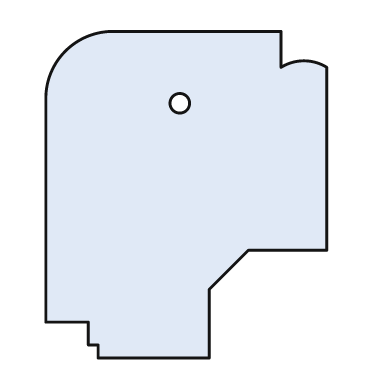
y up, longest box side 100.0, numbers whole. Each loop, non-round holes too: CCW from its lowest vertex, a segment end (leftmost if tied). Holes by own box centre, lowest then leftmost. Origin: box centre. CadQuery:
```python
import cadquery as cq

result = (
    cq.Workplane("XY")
    .moveTo(-27.0, -50.0)
    .lineTo(7.0, -50.0)
    .lineTo(7.0, -29.0)
    .lineTo(19.0, -17.0)
    .lineTo(43.0, -17.0)
    .lineTo(43.0, 39.0)
    .threePointArc((36.0, 41.0), (29.0, 39.0))
    .lineTo(29.0, 50.0)
    .lineTo(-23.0, 50.0)
    .threePointArc((-37.0, 44.0), (-43.0, 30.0))
    .lineTo(-43.0, -39.0)
    .lineTo(-30.0, -39.0)
    .lineTo(-30.0, -46.0)
    .lineTo(-27.0, -46.0)
    .close()
    .moveTo(-2.0, 28.0)
    .circle(3.0)
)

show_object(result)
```